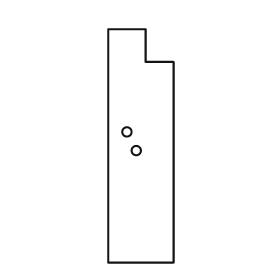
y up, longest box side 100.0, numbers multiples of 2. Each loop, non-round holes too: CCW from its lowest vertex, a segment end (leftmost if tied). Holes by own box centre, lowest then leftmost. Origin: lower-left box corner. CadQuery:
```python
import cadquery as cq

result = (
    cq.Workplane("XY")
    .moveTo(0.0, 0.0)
    .lineTo(28.0, 0.0)
    .lineTo(28.0, 86.0)
    .lineTo(16.0, 86.0)
    .lineTo(16.0, 100.0)
    .lineTo(0.0, 100.0)
    .close()
    .moveTo(12.0, 48.0)
    .circle(2.0)
    .moveTo(8.0, 56.0)
    .circle(2.0)
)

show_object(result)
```